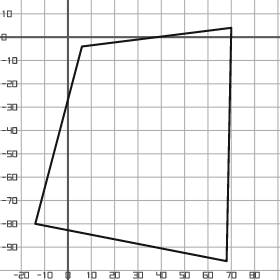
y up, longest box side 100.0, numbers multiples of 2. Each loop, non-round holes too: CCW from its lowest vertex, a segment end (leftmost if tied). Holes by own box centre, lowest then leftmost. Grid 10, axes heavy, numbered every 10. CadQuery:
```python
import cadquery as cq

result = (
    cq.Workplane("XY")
    .moveTo(68.0, -96.0)
    .lineTo(70.0, 4.0)
    .lineTo(6.0, -4.0)
    .lineTo(-14.0, -80.0)
    .close()
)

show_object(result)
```